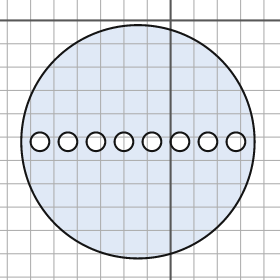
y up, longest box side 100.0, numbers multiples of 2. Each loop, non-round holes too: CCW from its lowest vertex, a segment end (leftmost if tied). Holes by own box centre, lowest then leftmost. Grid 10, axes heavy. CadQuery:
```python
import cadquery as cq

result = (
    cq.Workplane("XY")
    .moveTo(-14.0, -52.0)
    .circle(50.0)
    .moveTo(-56.0, -52.0)
    .circle(4.0)
    .moveTo(-44.0, -52.0)
    .circle(4.0)
    .moveTo(-32.0, -52.0)
    .circle(4.0)
    .moveTo(-20.0, -52.0)
    .circle(4.0)
    .moveTo(-8.0, -52.0)
    .circle(4.0)
    .moveTo(4.0, -52.0)
    .circle(4.0)
    .moveTo(16.0, -52.0)
    .circle(4.0)
    .moveTo(28.0, -52.0)
    .circle(4.0)
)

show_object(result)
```